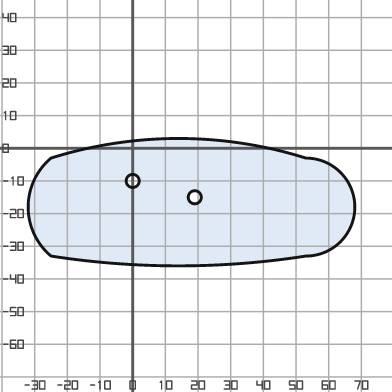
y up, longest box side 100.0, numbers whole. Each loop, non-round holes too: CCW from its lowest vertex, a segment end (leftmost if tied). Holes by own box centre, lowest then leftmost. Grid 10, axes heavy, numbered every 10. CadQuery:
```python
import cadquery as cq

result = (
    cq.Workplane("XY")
    .moveTo(-25.0, -33.0)
    .threePointArc((14.0, -36.0), (53.0, -33.0))
    .threePointArc((68.0, -18.0), (53.0, -3.0))
    .threePointArc((14.0, 3.0), (-25.0, -3.0))
    .threePointArc((-32.0, -18.0), (-25.0, -33.0))
    .close()
    .moveTo(19.0, -15.0)
    .circle(2.0)
    .moveTo(0.0, -10.0)
    .circle(2.0)
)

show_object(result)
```